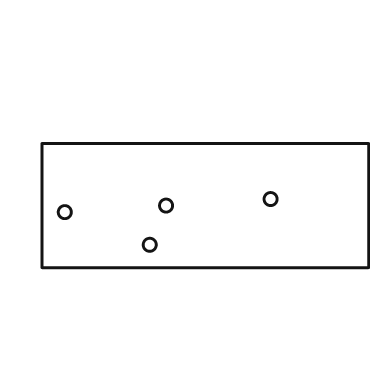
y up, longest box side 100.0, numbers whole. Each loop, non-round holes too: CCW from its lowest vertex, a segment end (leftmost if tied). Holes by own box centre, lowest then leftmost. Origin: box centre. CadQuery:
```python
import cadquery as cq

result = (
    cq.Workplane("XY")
    .moveTo(-50.0, -19.0)
    .lineTo(50.0, -19.0)
    .lineTo(50.0, 19.0)
    .lineTo(-50.0, 19.0)
    .close()
    .moveTo(-17.0, -12.0)
    .circle(2.0)
    .moveTo(-43.0, -2.0)
    .circle(2.0)
    .moveTo(-12.0, 0.0)
    .circle(2.0)
    .moveTo(20.0, 2.0)
    .circle(2.0)
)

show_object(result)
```